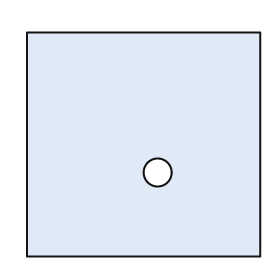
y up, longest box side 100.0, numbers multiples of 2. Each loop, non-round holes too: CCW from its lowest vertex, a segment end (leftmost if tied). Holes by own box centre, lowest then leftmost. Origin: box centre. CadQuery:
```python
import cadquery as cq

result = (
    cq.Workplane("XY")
    .moveTo(-50.0, -48.0)
    .lineTo(50.0, -48.0)
    .lineTo(50.0, 48.0)
    .lineTo(-50.0, 48.0)
    .close()
    .moveTo(6.0, -12.0)
    .circle(6.0)
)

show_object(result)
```